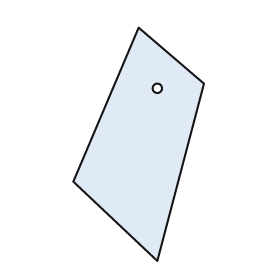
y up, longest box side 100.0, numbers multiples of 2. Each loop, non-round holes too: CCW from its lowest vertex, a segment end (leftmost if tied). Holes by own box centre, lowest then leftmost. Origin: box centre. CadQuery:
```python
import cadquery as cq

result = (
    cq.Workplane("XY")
    .moveTo(8.0, -50.0)
    .lineTo(28.0, 26.0)
    .lineTo(0.0, 50.0)
    .lineTo(-28.0, -16.0)
    .close()
    .moveTo(8.0, 24.0)
    .circle(2.0)
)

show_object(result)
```